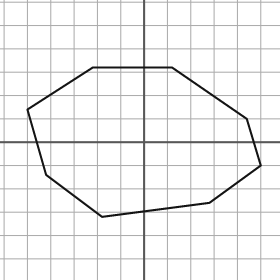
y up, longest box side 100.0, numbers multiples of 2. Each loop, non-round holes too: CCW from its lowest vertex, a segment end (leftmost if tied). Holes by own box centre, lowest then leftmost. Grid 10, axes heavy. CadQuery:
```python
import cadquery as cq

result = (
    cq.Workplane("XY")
    .moveTo(-18.0, -32.0)
    .lineTo(28.0, -26.0)
    .lineTo(50.0, -10.0)
    .lineTo(44.0, 10.0)
    .lineTo(12.0, 32.0)
    .lineTo(-22.0, 32.0)
    .lineTo(-50.0, 14.0)
    .lineTo(-42.0, -14.0)
    .close()
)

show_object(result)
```